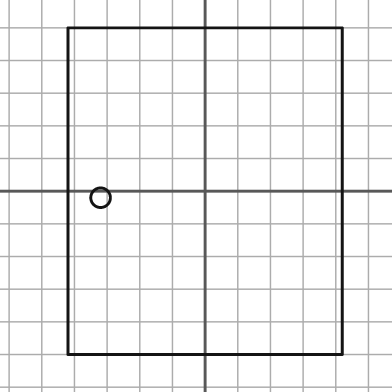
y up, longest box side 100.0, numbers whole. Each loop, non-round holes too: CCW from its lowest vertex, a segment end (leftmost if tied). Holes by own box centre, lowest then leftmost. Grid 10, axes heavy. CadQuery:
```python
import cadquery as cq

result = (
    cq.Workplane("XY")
    .moveTo(-42.0, -50.0)
    .lineTo(42.0, -50.0)
    .lineTo(42.0, 50.0)
    .lineTo(-42.0, 50.0)
    .close()
    .moveTo(-32.0, -2.0)
    .circle(3.0)
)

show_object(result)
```